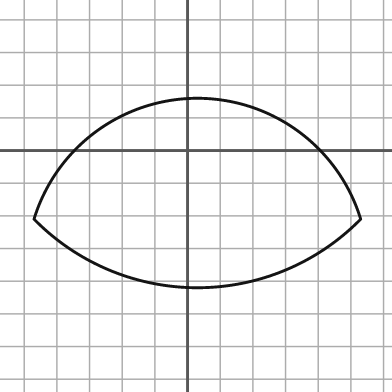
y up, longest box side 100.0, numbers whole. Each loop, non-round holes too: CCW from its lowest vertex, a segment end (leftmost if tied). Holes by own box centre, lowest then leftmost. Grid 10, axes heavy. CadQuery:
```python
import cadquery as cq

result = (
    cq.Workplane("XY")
    .moveTo(-47.0, -21.0)
    .threePointArc((3.0, -42.0), (53.0, -21.0))
    .threePointArc((3.0, 16.0), (-47.0, -21.0))
    .close()
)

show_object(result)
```